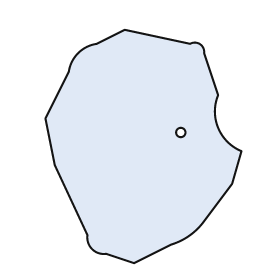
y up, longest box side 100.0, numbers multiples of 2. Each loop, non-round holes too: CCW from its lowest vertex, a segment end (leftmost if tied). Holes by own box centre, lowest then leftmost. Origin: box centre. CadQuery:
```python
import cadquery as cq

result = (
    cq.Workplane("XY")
    .moveTo(-4.0, -50.0)
    .lineTo(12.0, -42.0)
    .threePointArc((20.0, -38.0), (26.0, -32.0))
    .lineTo(38.0, -16.0)
    .lineTo(42.0, -2.0)
    .threePointArc((32.0, 8.0), (32.0, 22.0))
    .lineTo(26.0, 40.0)
    .threePointArc((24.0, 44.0), (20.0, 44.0))
    .lineTo(-8.0, 50.0)
    .lineTo(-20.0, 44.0)
    .threePointArc((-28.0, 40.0), (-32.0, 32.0))
    .lineTo(-42.0, 12.0)
    .lineTo(-38.0, -8.0)
    .lineTo(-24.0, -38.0)
    .threePointArc((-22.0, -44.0), (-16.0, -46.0))
    .close()
    .moveTo(16.0, 6.0)
    .circle(2.0)
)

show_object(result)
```